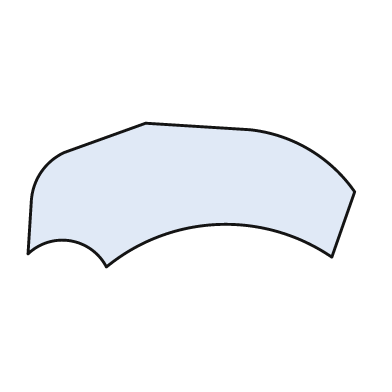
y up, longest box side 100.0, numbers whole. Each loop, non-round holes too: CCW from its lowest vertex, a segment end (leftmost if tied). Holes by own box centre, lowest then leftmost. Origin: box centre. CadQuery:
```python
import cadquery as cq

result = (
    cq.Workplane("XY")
    .moveTo(-26.0, -22.0)
    .threePointArc((8.0, -9.0), (43.0, -19.0))
    .lineTo(50.0, 1.0)
    .threePointArc((36.0, 14.0), (18.0, 20.0))
    .lineTo(-14.0, 22.0)
    .lineTo(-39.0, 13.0)
    .threePointArc((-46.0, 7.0), (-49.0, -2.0))
    .lineTo(-50.0, -18.0)
    .threePointArc((-37.0, -14.0), (-26.0, -22.0))
    .close()
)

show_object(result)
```